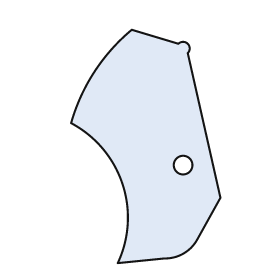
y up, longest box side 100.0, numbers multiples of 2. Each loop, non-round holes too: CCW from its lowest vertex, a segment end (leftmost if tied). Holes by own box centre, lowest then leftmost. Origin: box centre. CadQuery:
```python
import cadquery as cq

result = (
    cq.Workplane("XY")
    .moveTo(-12.0, -50.0)
    .lineTo(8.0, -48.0)
    .threePointArc((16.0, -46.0), (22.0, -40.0))
    .lineTo(32.0, -22.0)
    .lineTo(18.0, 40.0)
    .threePointArc((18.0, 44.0), (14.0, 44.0))
    .lineTo(-6.0, 50.0)
    .threePointArc((-22.0, 32.0), (-32.0, 10.0))
    .threePointArc((-10.0, -16.0), (-12.0, -50.0))
    .close()
    .moveTo(16.0, -8.0)
    .circle(4.0)
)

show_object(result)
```